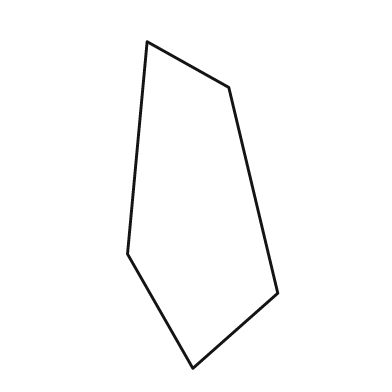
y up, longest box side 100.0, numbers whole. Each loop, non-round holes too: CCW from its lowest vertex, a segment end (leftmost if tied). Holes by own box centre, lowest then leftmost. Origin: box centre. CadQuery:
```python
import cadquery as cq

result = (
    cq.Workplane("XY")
    .moveTo(-3.0, -50.0)
    .lineTo(23.0, -27.0)
    .lineTo(8.0, 36.0)
    .lineTo(-17.0, 50.0)
    .lineTo(-23.0, -15.0)
    .close()
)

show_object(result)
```